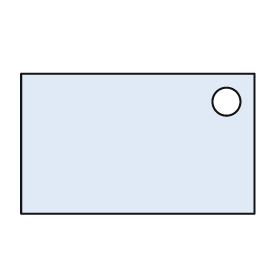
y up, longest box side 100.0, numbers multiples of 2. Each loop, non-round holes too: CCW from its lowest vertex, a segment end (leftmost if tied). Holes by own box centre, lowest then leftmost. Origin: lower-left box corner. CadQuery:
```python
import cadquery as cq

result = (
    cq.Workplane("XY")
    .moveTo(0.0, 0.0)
    .lineTo(100.0, 0.0)
    .lineTo(100.0, 60.0)
    .lineTo(0.0, 60.0)
    .close()
    .moveTo(88.0, 48.0)
    .circle(6.0)
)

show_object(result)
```